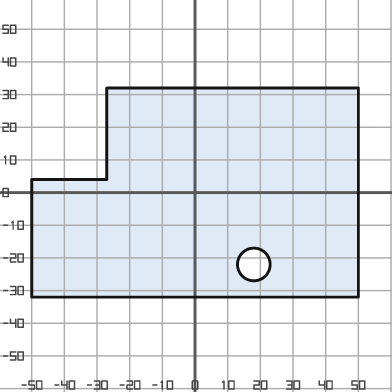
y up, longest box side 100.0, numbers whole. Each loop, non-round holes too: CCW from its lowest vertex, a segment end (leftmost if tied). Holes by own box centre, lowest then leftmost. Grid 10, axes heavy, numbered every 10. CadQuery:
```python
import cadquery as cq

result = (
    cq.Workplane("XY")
    .moveTo(-50.0, -32.0)
    .lineTo(50.0, -32.0)
    .lineTo(50.0, 32.0)
    .lineTo(-27.0, 32.0)
    .lineTo(-27.0, 4.0)
    .lineTo(-50.0, 4.0)
    .close()
    .moveTo(18.0, -22.0)
    .circle(5.0)
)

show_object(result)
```